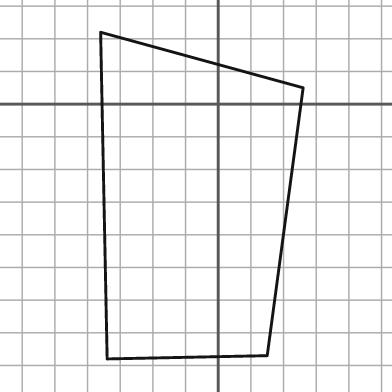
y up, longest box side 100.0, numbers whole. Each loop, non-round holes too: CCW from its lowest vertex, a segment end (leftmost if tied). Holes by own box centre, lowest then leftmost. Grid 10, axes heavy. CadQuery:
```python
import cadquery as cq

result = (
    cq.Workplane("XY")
    .moveTo(-34.0, -78.0)
    .lineTo(15.0, -77.0)
    .lineTo(26.0, 5.0)
    .lineTo(-36.0, 22.0)
    .close()
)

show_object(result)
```